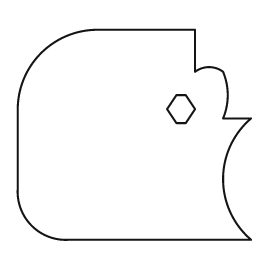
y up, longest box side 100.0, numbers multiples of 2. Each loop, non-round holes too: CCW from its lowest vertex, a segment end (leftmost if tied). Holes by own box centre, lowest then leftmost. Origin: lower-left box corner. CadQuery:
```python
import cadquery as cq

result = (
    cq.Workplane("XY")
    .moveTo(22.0, 0.0)
    .lineTo(100.0, 0.0)
    .threePointArc((88.0, 26.0), (100.0, 52.0))
    .lineTo(88.0, 52.0)
    .threePointArc((90.0, 62.0), (88.0, 72.0))
    .threePointArc((82.0, 74.0), (76.0, 72.0))
    .lineTo(76.0, 90.0)
    .lineTo(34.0, 90.0)
    .threePointArc((10.0, 80.0), (0.0, 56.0))
    .lineTo(0.0, 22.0)
    .threePointArc((6.0, 6.0), (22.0, 0.0))
    .close()
    .moveTo(68.0, 50.0)
    .lineTo(72.0, 50.0)
    .lineTo(76.0, 56.0)
    .lineTo(72.0, 62.0)
    .lineTo(68.0, 62.0)
    .lineTo(64.0, 56.0)
    .close()
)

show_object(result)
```